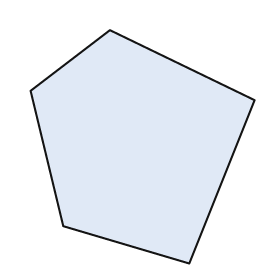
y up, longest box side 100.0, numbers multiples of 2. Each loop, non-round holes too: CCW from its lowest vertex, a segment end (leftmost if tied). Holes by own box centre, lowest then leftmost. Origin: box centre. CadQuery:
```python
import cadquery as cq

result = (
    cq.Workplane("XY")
    .moveTo(20.0, -50.0)
    .lineTo(48.0, 20.0)
    .lineTo(-14.0, 50.0)
    .lineTo(-48.0, 24.0)
    .lineTo(-34.0, -34.0)
    .close()
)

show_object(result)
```